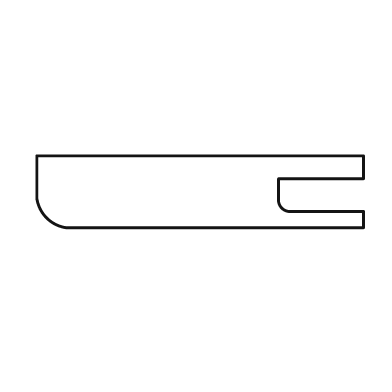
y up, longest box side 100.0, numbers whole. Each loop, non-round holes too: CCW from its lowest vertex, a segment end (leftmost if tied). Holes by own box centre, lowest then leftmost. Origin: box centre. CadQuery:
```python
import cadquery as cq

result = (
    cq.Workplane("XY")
    .moveTo(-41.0, -11.0)
    .lineTo(50.0, -11.0)
    .lineTo(50.0, -6.0)
    .lineTo(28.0, -6.0)
    .threePointArc((25.0, -5.0), (24.0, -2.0))
    .lineTo(24.0, 4.0)
    .lineTo(50.0, 4.0)
    .lineTo(50.0, 11.0)
    .lineTo(-50.0, 11.0)
    .lineTo(-50.0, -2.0)
    .threePointArc((-47.0, -8.0), (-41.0, -11.0))
    .close()
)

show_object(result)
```